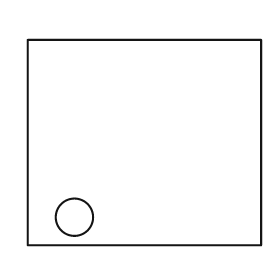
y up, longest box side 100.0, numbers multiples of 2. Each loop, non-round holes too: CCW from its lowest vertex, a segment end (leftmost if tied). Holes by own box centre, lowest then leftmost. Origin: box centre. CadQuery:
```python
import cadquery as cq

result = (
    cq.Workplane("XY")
    .moveTo(-50.0, -44.0)
    .lineTo(50.0, -44.0)
    .lineTo(50.0, 44.0)
    .lineTo(-50.0, 44.0)
    .close()
    .moveTo(-30.0, -32.0)
    .circle(8.0)
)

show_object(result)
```